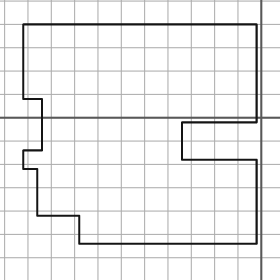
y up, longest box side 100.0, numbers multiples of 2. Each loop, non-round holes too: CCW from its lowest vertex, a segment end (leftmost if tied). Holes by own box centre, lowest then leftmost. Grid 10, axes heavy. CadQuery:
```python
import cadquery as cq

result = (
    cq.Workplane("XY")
    .moveTo(-78.0, -54.0)
    .lineTo(-2.0, -54.0)
    .lineTo(-2.0, -18.0)
    .lineTo(-34.0, -18.0)
    .lineTo(-34.0, -2.0)
    .lineTo(-2.0, -2.0)
    .lineTo(-2.0, 40.0)
    .lineTo(-102.0, 40.0)
    .lineTo(-102.0, 8.0)
    .lineTo(-94.0, 8.0)
    .lineTo(-94.0, -14.0)
    .lineTo(-102.0, -14.0)
    .lineTo(-102.0, -22.0)
    .lineTo(-96.0, -22.0)
    .lineTo(-96.0, -42.0)
    .lineTo(-78.0, -42.0)
    .close()
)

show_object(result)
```